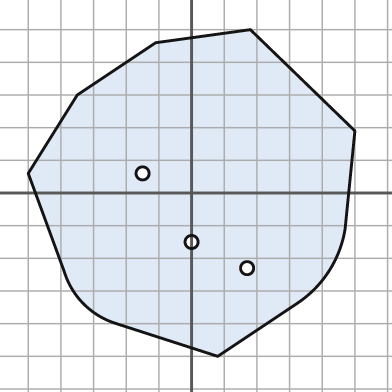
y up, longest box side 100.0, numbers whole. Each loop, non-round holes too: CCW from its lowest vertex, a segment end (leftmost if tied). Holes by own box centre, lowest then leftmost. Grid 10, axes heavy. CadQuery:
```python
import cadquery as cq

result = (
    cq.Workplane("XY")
    .moveTo(8.0, -50.0)
    .lineTo(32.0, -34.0)
    .threePointArc((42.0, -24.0), (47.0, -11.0))
    .lineTo(50.0, 19.0)
    .lineTo(18.0, 50.0)
    .lineTo(-11.0, 46.0)
    .lineTo(-35.0, 30.0)
    .lineTo(-50.0, 6.0)
    .lineTo(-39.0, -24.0)
    .threePointArc((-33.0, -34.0), (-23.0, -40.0))
    .close()
    .moveTo(17.0, -23.0)
    .circle(2.0)
    .moveTo(0.0, -15.0)
    .circle(2.0)
    .moveTo(-15.0, 6.0)
    .circle(2.0)
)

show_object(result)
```